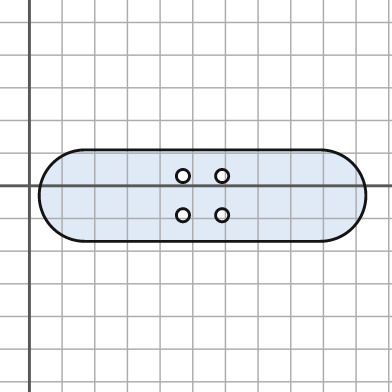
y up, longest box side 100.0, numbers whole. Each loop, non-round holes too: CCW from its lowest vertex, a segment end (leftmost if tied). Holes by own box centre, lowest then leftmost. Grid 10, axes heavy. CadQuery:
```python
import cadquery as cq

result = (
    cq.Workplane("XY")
    .moveTo(17.0, -17.0)
    .lineTo(89.0, -17.0)
    .threePointArc((103.0, -3.0), (89.0, 11.0))
    .lineTo(17.0, 11.0)
    .threePointArc((3.0, -3.0), (17.0, -17.0))
    .close()
    .moveTo(47.0, -9.0)
    .circle(2.0)
    .moveTo(59.0, -9.0)
    .circle(2.0)
    .moveTo(47.0, 3.0)
    .circle(2.0)
    .moveTo(59.0, 3.0)
    .circle(2.0)
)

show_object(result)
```